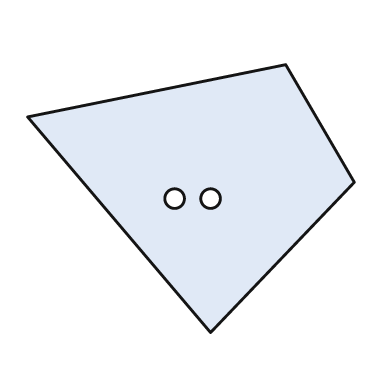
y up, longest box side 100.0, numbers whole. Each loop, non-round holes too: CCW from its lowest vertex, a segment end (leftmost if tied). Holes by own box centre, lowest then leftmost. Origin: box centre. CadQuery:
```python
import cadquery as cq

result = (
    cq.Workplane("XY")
    .moveTo(6.0, -41.0)
    .lineTo(50.0, 5.0)
    .lineTo(29.0, 41.0)
    .lineTo(-50.0, 25.0)
    .close()
    .moveTo(-5.0, 0.0)
    .circle(3.0)
    .moveTo(6.0, 0.0)
    .circle(3.0)
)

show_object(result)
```